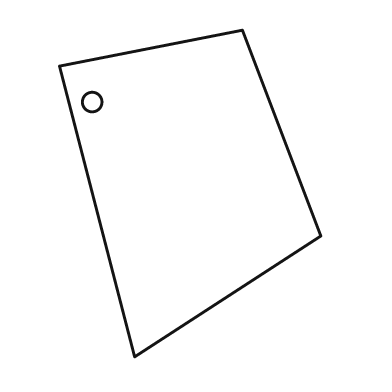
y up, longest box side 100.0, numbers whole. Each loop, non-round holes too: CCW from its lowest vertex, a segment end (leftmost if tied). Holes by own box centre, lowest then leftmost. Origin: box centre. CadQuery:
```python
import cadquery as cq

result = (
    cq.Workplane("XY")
    .moveTo(-17.0, -50.0)
    .lineTo(40.0, -13.0)
    .lineTo(16.0, 50.0)
    .lineTo(-40.0, 39.0)
    .close()
    .moveTo(-30.0, 28.0)
    .circle(3.0)
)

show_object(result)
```